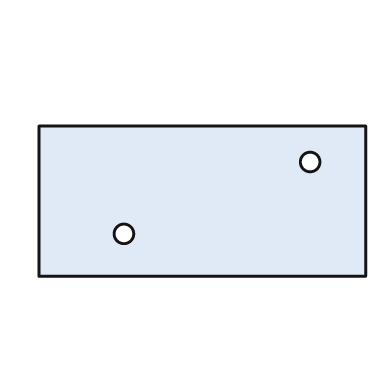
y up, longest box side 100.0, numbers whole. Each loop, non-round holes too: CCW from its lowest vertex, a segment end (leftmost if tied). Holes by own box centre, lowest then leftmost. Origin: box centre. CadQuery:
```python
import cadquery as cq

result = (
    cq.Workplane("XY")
    .moveTo(-50.0, -23.0)
    .lineTo(50.0, -23.0)
    .lineTo(50.0, 23.0)
    .lineTo(-50.0, 23.0)
    .close()
    .moveTo(-24.0, -10.0)
    .circle(3.0)
    .moveTo(33.0, 12.0)
    .circle(3.0)
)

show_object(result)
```